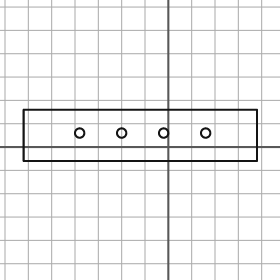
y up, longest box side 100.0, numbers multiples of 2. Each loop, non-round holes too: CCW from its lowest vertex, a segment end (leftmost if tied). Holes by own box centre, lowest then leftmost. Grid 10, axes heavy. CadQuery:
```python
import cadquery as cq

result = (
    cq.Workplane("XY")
    .moveTo(-62.0, -6.0)
    .lineTo(38.0, -6.0)
    .lineTo(38.0, 16.0)
    .lineTo(-62.0, 16.0)
    .close()
    .moveTo(-38.0, 6.0)
    .circle(2.0)
    .moveTo(-20.0, 6.0)
    .circle(2.0)
    .moveTo(-2.0, 6.0)
    .circle(2.0)
    .moveTo(16.0, 6.0)
    .circle(2.0)
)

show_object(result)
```